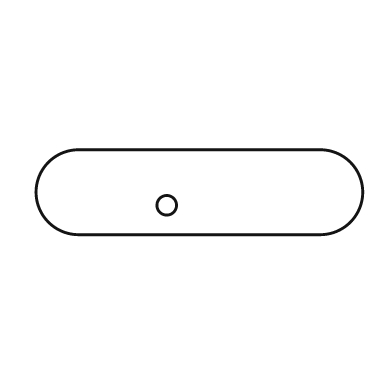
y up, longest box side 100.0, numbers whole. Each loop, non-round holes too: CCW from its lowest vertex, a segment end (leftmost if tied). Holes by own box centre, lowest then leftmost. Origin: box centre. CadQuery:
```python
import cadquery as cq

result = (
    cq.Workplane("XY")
    .moveTo(-37.0, -13.0)
    .lineTo(37.0, -13.0)
    .threePointArc((50.0, 0.0), (37.0, 13.0))
    .lineTo(-37.0, 13.0)
    .threePointArc((-50.0, 0.0), (-37.0, -13.0))
    .close()
    .moveTo(-10.0, -4.0)
    .circle(3.0)
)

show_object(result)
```